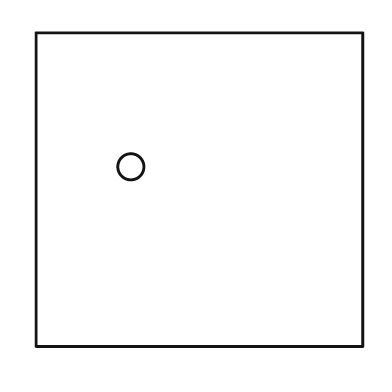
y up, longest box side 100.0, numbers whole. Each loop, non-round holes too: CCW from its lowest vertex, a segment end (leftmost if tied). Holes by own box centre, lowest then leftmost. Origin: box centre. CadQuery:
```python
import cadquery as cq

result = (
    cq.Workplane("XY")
    .moveTo(-50.0, -48.0)
    .lineTo(50.0, -48.0)
    .lineTo(50.0, 48.0)
    .lineTo(-50.0, 48.0)
    .close()
    .moveTo(-21.0, 7.0)
    .circle(4.0)
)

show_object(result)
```